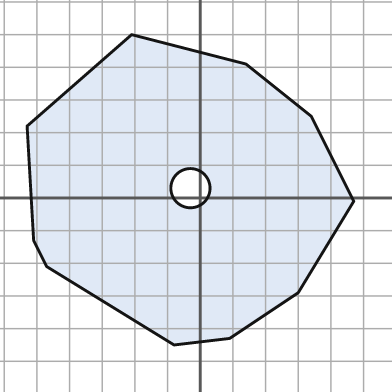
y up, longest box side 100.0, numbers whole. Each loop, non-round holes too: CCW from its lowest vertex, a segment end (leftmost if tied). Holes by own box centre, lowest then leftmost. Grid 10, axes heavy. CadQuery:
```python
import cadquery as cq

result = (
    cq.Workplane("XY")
    .moveTo(-8.0, -45.0)
    .lineTo(9.0, -43.0)
    .lineTo(30.0, -29.0)
    .lineTo(47.0, -1.0)
    .lineTo(34.0, 25.0)
    .lineTo(14.0, 41.0)
    .lineTo(-21.0, 50.0)
    .lineTo(-53.0, 22.0)
    .lineTo(-51.0, -13.0)
    .lineTo(-47.0, -21.0)
    .close()
    .moveTo(-3.0, 3.0)
    .circle(6.0)
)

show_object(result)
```